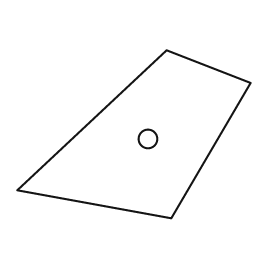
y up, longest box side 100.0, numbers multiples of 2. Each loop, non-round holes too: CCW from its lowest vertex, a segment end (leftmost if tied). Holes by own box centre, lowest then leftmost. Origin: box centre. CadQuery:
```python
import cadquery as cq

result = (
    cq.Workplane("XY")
    .moveTo(16.0, -36.0)
    .lineTo(50.0, 22.0)
    .lineTo(14.0, 36.0)
    .lineTo(-50.0, -24.0)
    .close()
    .moveTo(6.0, -2.0)
    .circle(4.0)
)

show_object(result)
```